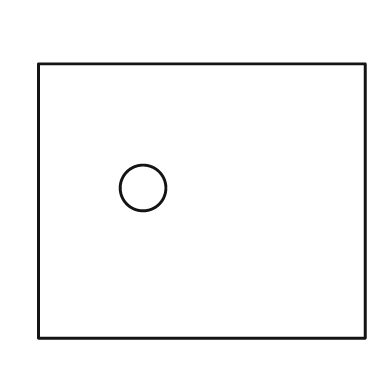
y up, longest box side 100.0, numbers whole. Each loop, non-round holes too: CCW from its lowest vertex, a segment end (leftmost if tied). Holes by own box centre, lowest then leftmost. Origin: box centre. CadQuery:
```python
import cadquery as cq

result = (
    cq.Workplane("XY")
    .moveTo(-50.0, -42.0)
    .lineTo(50.0, -42.0)
    .lineTo(50.0, 42.0)
    .lineTo(-50.0, 42.0)
    .close()
    .moveTo(-18.0, 4.0)
    .circle(7.0)
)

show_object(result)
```